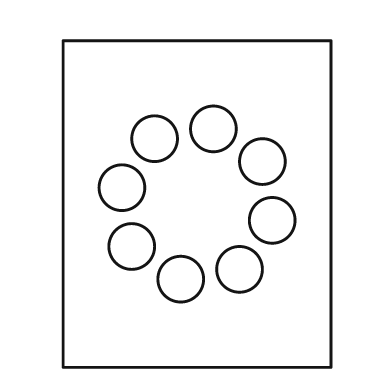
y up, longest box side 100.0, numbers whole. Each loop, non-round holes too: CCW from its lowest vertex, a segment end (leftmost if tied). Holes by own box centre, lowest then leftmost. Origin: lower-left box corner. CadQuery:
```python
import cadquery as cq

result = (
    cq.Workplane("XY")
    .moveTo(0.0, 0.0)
    .lineTo(82.0, 0.0)
    .lineTo(82.0, 100.0)
    .lineTo(0.0, 100.0)
    .close()
    .moveTo(36.0, 27.0)
    .circle(7.0)
    .moveTo(54.0, 30.0)
    .circle(7.0)
    .moveTo(21.0, 37.0)
    .circle(7.0)
    .moveTo(64.0, 45.0)
    .circle(7.0)
    .moveTo(18.0, 55.0)
    .circle(7.0)
    .moveTo(61.0, 63.0)
    .circle(7.0)
    .moveTo(28.0, 70.0)
    .circle(7.0)
    .moveTo(46.0, 73.0)
    .circle(7.0)
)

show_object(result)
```